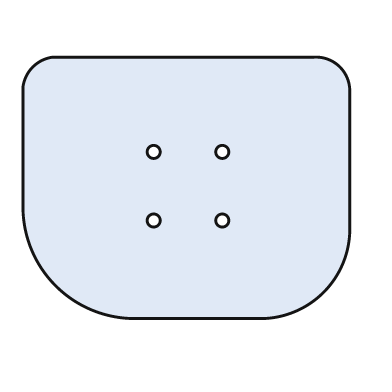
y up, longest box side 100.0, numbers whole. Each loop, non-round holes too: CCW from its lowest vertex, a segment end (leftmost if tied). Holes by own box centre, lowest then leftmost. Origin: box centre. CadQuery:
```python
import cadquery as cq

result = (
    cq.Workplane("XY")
    .moveTo(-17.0, -40.0)
    .lineTo(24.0, -40.0)
    .threePointArc((42.0, -32.0), (50.0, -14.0))
    .lineTo(50.0, 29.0)
    .threePointArc((47.0, 37.0), (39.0, 40.0))
    .lineTo(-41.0, 40.0)
    .threePointArc((-47.0, 37.0), (-50.0, 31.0))
    .lineTo(-50.0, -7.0)
    .threePointArc((-40.0, -30.0), (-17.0, -40.0))
    .close()
    .moveTo(-10.0, -10.0)
    .circle(2.0)
    .moveTo(11.0, -10.0)
    .circle(2.0)
    .moveTo(-10.0, 11.0)
    .circle(2.0)
    .moveTo(11.0, 11.0)
    .circle(2.0)
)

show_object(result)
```